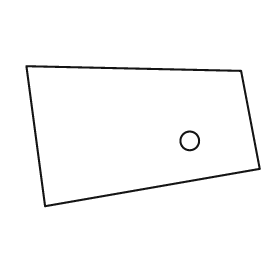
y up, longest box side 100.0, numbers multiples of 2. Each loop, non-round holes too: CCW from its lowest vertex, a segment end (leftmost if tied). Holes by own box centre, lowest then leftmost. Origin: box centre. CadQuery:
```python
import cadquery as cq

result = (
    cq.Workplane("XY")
    .moveTo(-42.0, -30.0)
    .lineTo(50.0, -14.0)
    .lineTo(42.0, 28.0)
    .lineTo(-50.0, 30.0)
    .close()
    .moveTo(20.0, -2.0)
    .circle(4.0)
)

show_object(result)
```